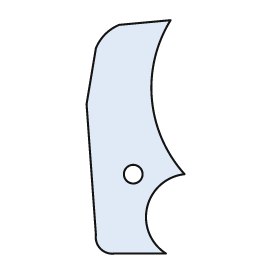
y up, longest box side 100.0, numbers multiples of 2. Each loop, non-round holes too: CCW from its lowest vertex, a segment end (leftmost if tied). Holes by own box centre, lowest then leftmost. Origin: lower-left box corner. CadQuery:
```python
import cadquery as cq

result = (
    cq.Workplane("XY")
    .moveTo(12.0, 0.0)
    .lineTo(34.0, 0.0)
    .threePointArc((26.0, 20.0), (42.0, 34.0))
    .threePointArc((28.0, 66.0), (36.0, 100.0))
    .lineTo(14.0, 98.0)
    .threePointArc((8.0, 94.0), (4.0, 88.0))
    .lineTo(0.0, 64.0)
    .lineTo(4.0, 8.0)
    .threePointArc((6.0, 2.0), (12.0, 0.0))
    .close()
    .moveTo(20.0, 34.0)
    .circle(4.0)
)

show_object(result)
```